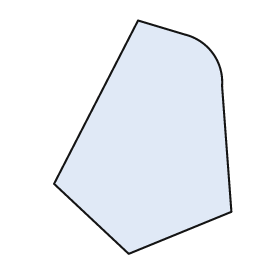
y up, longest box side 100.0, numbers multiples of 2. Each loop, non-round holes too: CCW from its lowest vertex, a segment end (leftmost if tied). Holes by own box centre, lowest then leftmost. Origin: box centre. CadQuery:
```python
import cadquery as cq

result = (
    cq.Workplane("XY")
    .moveTo(-6.0, -50.0)
    .lineTo(38.0, -32.0)
    .lineTo(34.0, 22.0)
    .threePointArc((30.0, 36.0), (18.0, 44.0))
    .lineTo(-2.0, 50.0)
    .lineTo(-38.0, -20.0)
    .close()
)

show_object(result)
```